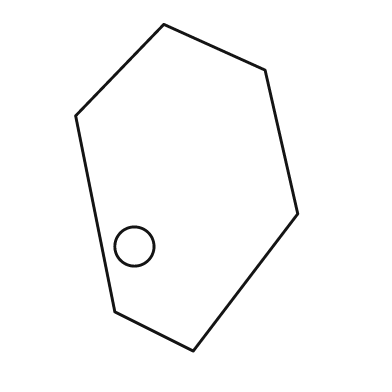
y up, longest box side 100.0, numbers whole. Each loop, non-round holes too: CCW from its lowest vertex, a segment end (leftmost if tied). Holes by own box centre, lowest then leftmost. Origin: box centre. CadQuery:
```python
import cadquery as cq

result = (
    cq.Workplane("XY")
    .moveTo(2.0, -50.0)
    .lineTo(34.0, -8.0)
    .lineTo(24.0, 36.0)
    .lineTo(-7.0, 50.0)
    .lineTo(-34.0, 22.0)
    .lineTo(-22.0, -38.0)
    .close()
    .moveTo(-16.0, -18.0)
    .circle(6.0)
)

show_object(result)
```